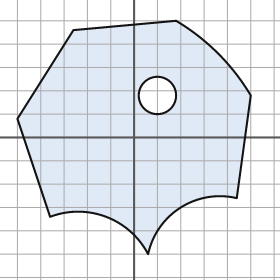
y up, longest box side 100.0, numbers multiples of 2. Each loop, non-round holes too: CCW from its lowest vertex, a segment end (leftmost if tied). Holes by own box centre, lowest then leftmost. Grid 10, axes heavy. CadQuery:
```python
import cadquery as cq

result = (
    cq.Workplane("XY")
    .moveTo(6.0, -50.0)
    .threePointArc((20.0, -30.0), (44.0, -26.0))
    .lineTo(50.0, 18.0)
    .threePointArc((36.0, 36.0), (18.0, 50.0))
    .lineTo(-26.0, 46.0)
    .lineTo(-50.0, 8.0)
    .lineTo(-36.0, -34.0)
    .threePointArc((-12.0, -34.0), (6.0, -50.0))
    .close()
    .moveTo(10.0, 18.0)
    .circle(8.0)
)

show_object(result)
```